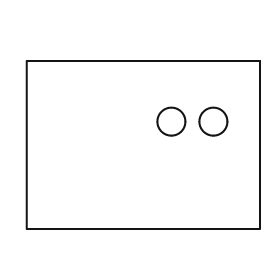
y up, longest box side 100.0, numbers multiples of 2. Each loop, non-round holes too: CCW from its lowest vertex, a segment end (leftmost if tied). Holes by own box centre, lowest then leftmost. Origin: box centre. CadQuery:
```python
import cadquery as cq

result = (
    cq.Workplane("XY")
    .moveTo(-50.0, -36.0)
    .lineTo(50.0, -36.0)
    .lineTo(50.0, 36.0)
    .lineTo(-50.0, 36.0)
    .close()
    .moveTo(12.0, 10.0)
    .circle(6.0)
    .moveTo(30.0, 10.0)
    .circle(6.0)
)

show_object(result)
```